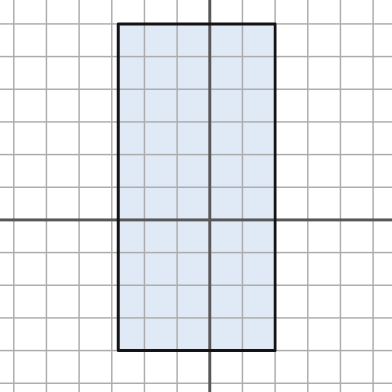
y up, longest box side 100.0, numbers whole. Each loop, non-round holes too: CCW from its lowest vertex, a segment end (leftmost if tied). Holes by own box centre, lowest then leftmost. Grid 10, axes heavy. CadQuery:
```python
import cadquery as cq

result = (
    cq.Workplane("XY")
    .moveTo(-28.0, -40.0)
    .lineTo(20.0, -40.0)
    .lineTo(20.0, 60.0)
    .lineTo(-28.0, 60.0)
    .close()
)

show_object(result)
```